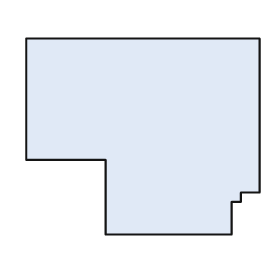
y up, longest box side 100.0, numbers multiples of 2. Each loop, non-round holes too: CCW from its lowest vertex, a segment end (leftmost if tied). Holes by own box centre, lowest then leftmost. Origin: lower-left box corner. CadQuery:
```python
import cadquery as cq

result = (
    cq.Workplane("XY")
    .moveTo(34.0, 0.0)
    .lineTo(88.0, 0.0)
    .lineTo(88.0, 14.0)
    .lineTo(92.0, 14.0)
    .lineTo(92.0, 18.0)
    .lineTo(100.0, 18.0)
    .lineTo(100.0, 84.0)
    .lineTo(0.0, 84.0)
    .lineTo(0.0, 32.0)
    .lineTo(34.0, 32.0)
    .close()
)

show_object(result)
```